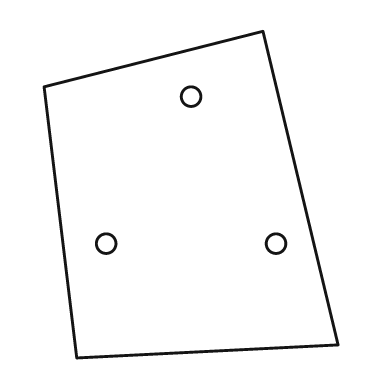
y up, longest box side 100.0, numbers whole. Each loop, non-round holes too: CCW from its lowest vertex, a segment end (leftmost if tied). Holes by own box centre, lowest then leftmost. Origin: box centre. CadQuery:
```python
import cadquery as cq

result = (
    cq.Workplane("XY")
    .moveTo(-35.0, -50.0)
    .lineTo(45.0, -46.0)
    .lineTo(22.0, 50.0)
    .lineTo(-45.0, 33.0)
    .close()
    .moveTo(-26.0, -15.0)
    .circle(3.0)
    .moveTo(26.0, -15.0)
    .circle(3.0)
    .moveTo(0.0, 30.0)
    .circle(3.0)
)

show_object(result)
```